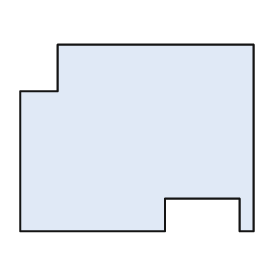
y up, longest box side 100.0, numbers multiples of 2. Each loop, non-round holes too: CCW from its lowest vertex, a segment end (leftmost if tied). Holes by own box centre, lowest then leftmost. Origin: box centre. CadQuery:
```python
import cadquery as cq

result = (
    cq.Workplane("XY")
    .moveTo(-50.0, -40.0)
    .lineTo(12.0, -40.0)
    .lineTo(12.0, -26.0)
    .lineTo(44.0, -26.0)
    .lineTo(44.0, -40.0)
    .lineTo(50.0, -40.0)
    .lineTo(50.0, 40.0)
    .lineTo(-34.0, 40.0)
    .lineTo(-34.0, 20.0)
    .lineTo(-50.0, 20.0)
    .close()
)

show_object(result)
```